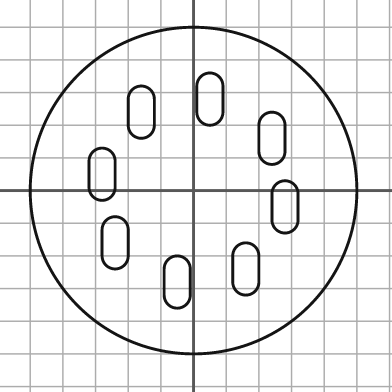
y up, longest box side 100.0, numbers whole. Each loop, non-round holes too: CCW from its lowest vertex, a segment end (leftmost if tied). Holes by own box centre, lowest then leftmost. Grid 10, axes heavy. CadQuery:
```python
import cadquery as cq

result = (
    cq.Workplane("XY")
    .moveTo(0.0, 0.0)
    .circle(50.0)
    .moveTo(-9.0, -32.0)
    .threePointArc((-5.0, -36.0), (-1.0, -32.0))
    .lineTo(-1.0, -24.0)
    .threePointArc((-5.0, -20.0), (-9.0, -24.0))
    .close()
    .moveTo(12.0, -28.0)
    .threePointArc((16.0, -32.0), (20.0, -28.0))
    .lineTo(20.0, -20.0)
    .threePointArc((16.0, -16.0), (12.0, -20.0))
    .close()
    .moveTo(-28.0, -20.0)
    .threePointArc((-24.0, -24.0), (-20.0, -20.0))
    .lineTo(-20.0, -12.0)
    .threePointArc((-24.0, -8.0), (-28.0, -12.0))
    .close()
    .moveTo(24.0, -9.0)
    .threePointArc((28.0, -13.0), (32.0, -9.0))
    .lineTo(32.0, -1.0)
    .threePointArc((28.0, 3.0), (24.0, -1.0))
    .close()
    .moveTo(-32.0, 1.0)
    .threePointArc((-28.0, -3.0), (-24.0, 1.0))
    .lineTo(-24.0, 9.0)
    .threePointArc((-28.0, 13.0), (-32.0, 9.0))
    .close()
    .moveTo(20.0, 12.0)
    .threePointArc((24.0, 8.0), (28.0, 12.0))
    .lineTo(28.0, 20.0)
    .threePointArc((24.0, 24.0), (20.0, 20.0))
    .close()
    .moveTo(-20.0, 20.0)
    .threePointArc((-16.0, 16.0), (-12.0, 20.0))
    .lineTo(-12.0, 28.0)
    .threePointArc((-16.0, 32.0), (-20.0, 28.0))
    .close()
    .moveTo(1.0, 24.0)
    .threePointArc((5.0, 20.0), (9.0, 24.0))
    .lineTo(9.0, 32.0)
    .threePointArc((5.0, 36.0), (1.0, 32.0))
    .close()
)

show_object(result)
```